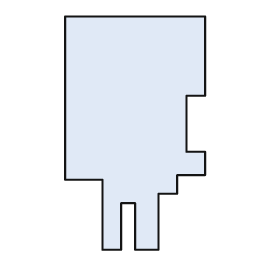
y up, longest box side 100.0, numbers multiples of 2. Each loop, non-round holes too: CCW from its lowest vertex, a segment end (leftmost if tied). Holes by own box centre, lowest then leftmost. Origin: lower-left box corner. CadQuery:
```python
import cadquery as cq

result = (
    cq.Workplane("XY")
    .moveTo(16.0, 0.0)
    .lineTo(24.0, 0.0)
    .lineTo(24.0, 20.0)
    .lineTo(30.0, 20.0)
    .lineTo(30.0, 0.0)
    .lineTo(40.0, 0.0)
    .lineTo(40.0, 24.0)
    .lineTo(48.0, 24.0)
    .lineTo(48.0, 32.0)
    .lineTo(60.0, 32.0)
    .lineTo(60.0, 42.0)
    .lineTo(52.0, 42.0)
    .lineTo(52.0, 66.0)
    .lineTo(60.0, 66.0)
    .lineTo(60.0, 100.0)
    .lineTo(0.0, 100.0)
    .lineTo(0.0, 30.0)
    .lineTo(16.0, 30.0)
    .close()
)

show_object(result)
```